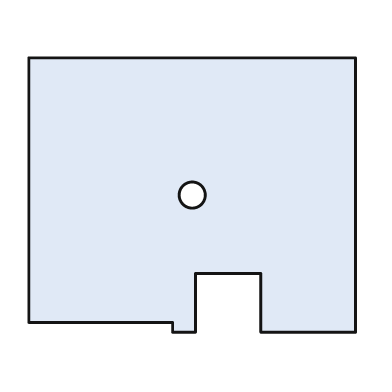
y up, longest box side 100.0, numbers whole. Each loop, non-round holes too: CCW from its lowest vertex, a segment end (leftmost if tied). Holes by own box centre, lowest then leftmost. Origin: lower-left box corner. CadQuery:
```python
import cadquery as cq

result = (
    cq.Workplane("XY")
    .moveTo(44.0, 0.0)
    .lineTo(51.0, 0.0)
    .lineTo(51.0, 18.0)
    .lineTo(71.0, 18.0)
    .lineTo(71.0, 0.0)
    .lineTo(100.0, 0.0)
    .lineTo(100.0, 84.0)
    .lineTo(0.0, 84.0)
    .lineTo(0.0, 3.0)
    .lineTo(44.0, 3.0)
    .close()
    .moveTo(50.0, 42.0)
    .circle(4.0)
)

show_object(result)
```